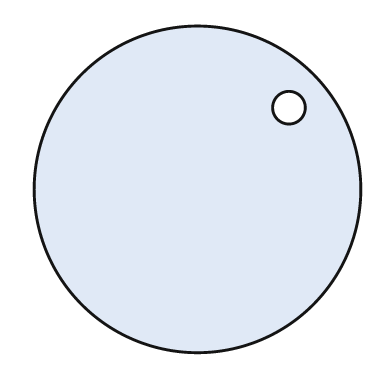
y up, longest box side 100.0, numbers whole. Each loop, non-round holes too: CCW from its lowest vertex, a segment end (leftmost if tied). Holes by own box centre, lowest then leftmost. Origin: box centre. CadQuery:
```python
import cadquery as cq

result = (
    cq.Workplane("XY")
    .moveTo(0.0, 0.0)
    .circle(50.0)
    .moveTo(28.0, 25.0)
    .circle(5.0)
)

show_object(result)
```